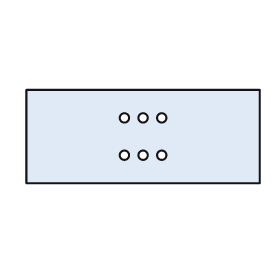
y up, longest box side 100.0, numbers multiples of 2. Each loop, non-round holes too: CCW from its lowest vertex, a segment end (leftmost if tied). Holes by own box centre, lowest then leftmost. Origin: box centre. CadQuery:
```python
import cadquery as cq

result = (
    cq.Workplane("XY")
    .moveTo(-50.0, -20.0)
    .lineTo(50.0, -20.0)
    .lineTo(50.0, 20.0)
    .lineTo(-50.0, 20.0)
    .close()
    .moveTo(-8.0, -8.0)
    .circle(2.0)
    .moveTo(0.0, -8.0)
    .circle(2.0)
    .moveTo(8.0, -8.0)
    .circle(2.0)
    .moveTo(-8.0, 8.0)
    .circle(2.0)
    .moveTo(0.0, 8.0)
    .circle(2.0)
    .moveTo(8.0, 8.0)
    .circle(2.0)
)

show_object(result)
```